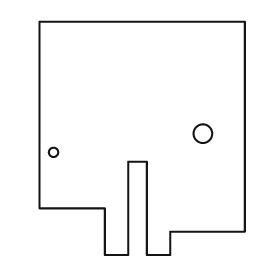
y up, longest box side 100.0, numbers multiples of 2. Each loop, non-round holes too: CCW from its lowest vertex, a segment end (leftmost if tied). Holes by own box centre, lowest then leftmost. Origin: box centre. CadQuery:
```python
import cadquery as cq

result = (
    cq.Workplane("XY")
    .moveTo(-16.0, -50.0)
    .lineTo(-6.0, -50.0)
    .lineTo(-6.0, -10.0)
    .lineTo(2.0, -10.0)
    .lineTo(2.0, -50.0)
    .lineTo(12.0, -50.0)
    .lineTo(12.0, -40.0)
    .lineTo(44.0, -40.0)
    .lineTo(44.0, 50.0)
    .lineTo(-44.0, 50.0)
    .lineTo(-44.0, -30.0)
    .lineTo(-16.0, -30.0)
    .close()
    .moveTo(-38.0, -6.0)
    .circle(2.0)
    .moveTo(26.0, 2.0)
    .circle(4.0)
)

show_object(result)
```